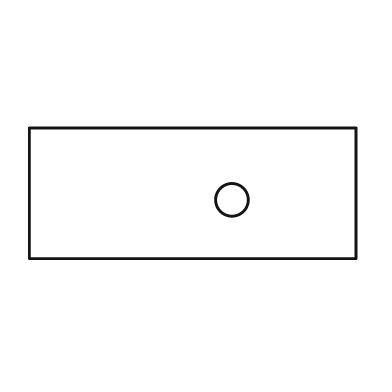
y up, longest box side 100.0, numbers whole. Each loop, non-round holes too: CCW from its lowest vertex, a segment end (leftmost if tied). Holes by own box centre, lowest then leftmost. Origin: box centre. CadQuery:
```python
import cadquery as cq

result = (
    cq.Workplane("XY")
    .moveTo(-50.0, -20.0)
    .lineTo(50.0, -20.0)
    .lineTo(50.0, 20.0)
    .lineTo(-50.0, 20.0)
    .close()
    .moveTo(12.0, -2.0)
    .circle(5.0)
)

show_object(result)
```